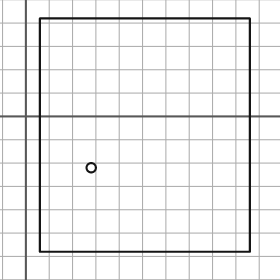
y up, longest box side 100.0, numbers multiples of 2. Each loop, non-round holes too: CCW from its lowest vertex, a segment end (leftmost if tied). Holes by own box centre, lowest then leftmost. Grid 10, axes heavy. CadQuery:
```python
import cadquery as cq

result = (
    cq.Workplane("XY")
    .moveTo(6.0, -58.0)
    .lineTo(96.0, -58.0)
    .lineTo(96.0, 42.0)
    .lineTo(6.0, 42.0)
    .close()
    .moveTo(28.0, -22.0)
    .circle(2.0)
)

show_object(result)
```